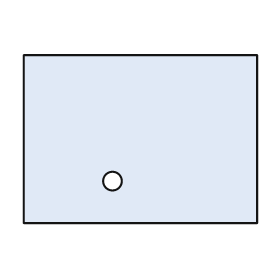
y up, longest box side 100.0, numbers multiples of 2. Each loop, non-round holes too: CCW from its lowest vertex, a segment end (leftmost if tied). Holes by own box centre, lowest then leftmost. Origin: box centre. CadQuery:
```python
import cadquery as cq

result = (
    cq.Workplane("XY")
    .moveTo(-50.0, -36.0)
    .lineTo(50.0, -36.0)
    .lineTo(50.0, 36.0)
    .lineTo(-50.0, 36.0)
    .close()
    .moveTo(-12.0, -18.0)
    .circle(4.0)
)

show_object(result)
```